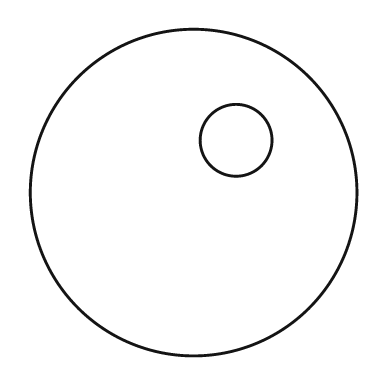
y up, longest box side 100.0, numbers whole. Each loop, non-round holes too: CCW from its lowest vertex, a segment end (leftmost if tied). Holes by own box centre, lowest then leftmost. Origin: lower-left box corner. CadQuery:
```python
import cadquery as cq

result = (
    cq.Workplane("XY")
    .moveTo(50.0, 50.0)
    .circle(50.0)
    .moveTo(63.0, 66.0)
    .circle(11.0)
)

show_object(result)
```